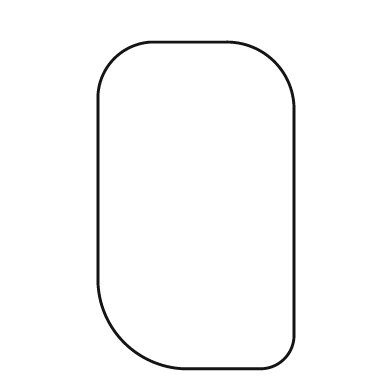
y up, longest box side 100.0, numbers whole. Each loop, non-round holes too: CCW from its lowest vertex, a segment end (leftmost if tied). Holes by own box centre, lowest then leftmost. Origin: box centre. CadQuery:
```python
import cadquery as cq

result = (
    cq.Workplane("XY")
    .moveTo(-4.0, -50.0)
    .lineTo(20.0, -50.0)
    .threePointArc((27.0, -47.0), (30.0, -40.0))
    .lineTo(30.0, 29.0)
    .threePointArc((24.0, 44.0), (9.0, 50.0))
    .lineTo(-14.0, 50.0)
    .threePointArc((-25.0, 45.0), (-30.0, 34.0))
    .lineTo(-30.0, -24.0)
    .threePointArc((-22.0, -42.0), (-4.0, -50.0))
    .close()
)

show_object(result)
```